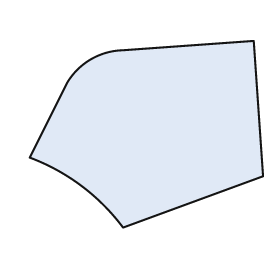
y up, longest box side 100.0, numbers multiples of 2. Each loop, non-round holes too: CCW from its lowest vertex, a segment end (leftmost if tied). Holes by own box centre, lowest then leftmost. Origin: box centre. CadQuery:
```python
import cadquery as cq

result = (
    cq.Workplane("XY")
    .moveTo(-10.0, -40.0)
    .lineTo(50.0, -18.0)
    .lineTo(46.0, 40.0)
    .lineTo(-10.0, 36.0)
    .threePointArc((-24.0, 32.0), (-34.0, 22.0))
    .lineTo(-50.0, -10.0)
    .threePointArc((-28.0, -22.0), (-10.0, -40.0))
    .close()
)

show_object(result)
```